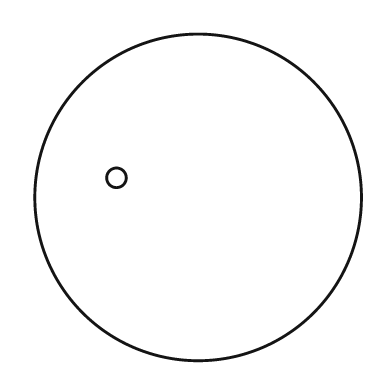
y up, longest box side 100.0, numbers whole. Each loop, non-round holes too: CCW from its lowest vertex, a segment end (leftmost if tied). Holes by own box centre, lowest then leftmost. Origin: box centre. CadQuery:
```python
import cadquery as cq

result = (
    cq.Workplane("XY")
    .moveTo(0.0, 0.0)
    .circle(50.0)
    .moveTo(-25.0, 6.0)
    .circle(3.0)
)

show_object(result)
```